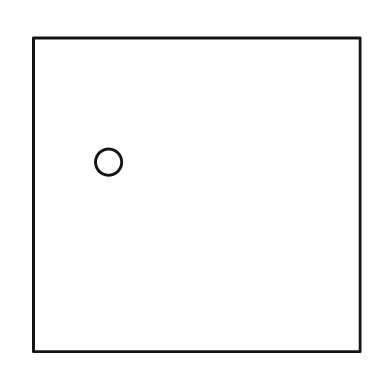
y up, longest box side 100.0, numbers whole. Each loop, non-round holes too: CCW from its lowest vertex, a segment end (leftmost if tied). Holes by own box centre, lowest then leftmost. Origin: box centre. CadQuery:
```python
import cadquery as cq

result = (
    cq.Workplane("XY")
    .moveTo(-50.0, -48.0)
    .lineTo(50.0, -48.0)
    .lineTo(50.0, 48.0)
    .lineTo(-50.0, 48.0)
    .close()
    .moveTo(-27.0, 10.0)
    .circle(4.0)
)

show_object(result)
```